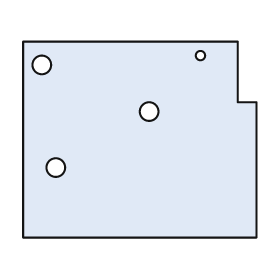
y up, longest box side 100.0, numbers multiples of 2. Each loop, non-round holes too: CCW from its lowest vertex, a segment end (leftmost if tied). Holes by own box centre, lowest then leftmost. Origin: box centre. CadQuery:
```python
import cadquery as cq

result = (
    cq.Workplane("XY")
    .moveTo(-50.0, -42.0)
    .lineTo(50.0, -42.0)
    .lineTo(50.0, 16.0)
    .lineTo(42.0, 16.0)
    .lineTo(42.0, 42.0)
    .lineTo(-50.0, 42.0)
    .close()
    .moveTo(-36.0, -12.0)
    .circle(4.0)
    .moveTo(4.0, 12.0)
    .circle(4.0)
    .moveTo(-42.0, 32.0)
    .circle(4.0)
    .moveTo(26.0, 36.0)
    .circle(2.0)
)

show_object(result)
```